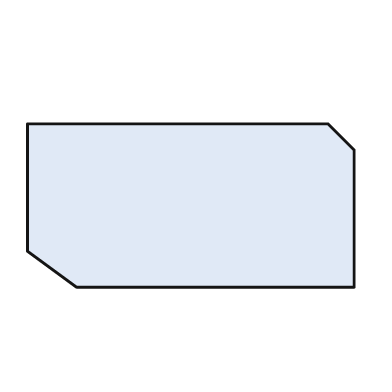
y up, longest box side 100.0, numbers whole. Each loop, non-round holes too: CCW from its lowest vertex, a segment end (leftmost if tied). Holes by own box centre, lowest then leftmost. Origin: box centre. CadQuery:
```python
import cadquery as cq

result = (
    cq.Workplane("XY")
    .moveTo(-35.0, -25.0)
    .lineTo(50.0, -25.0)
    .lineTo(50.0, 17.0)
    .lineTo(42.0, 25.0)
    .lineTo(-50.0, 25.0)
    .lineTo(-50.0, -14.0)
    .close()
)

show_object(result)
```